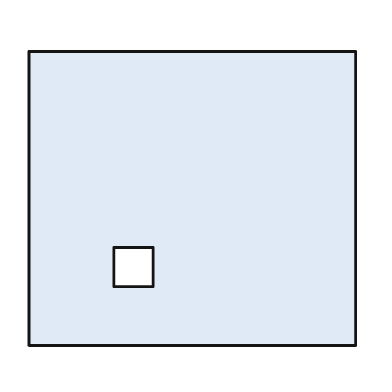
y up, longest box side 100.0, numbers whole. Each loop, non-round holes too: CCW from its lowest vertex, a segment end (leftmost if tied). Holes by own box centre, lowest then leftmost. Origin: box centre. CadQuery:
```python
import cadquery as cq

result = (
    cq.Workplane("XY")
    .moveTo(-50.0, -45.0)
    .lineTo(50.0, -45.0)
    .lineTo(50.0, 45.0)
    .lineTo(-50.0, 45.0)
    .close()
    .moveTo(-24.0, -27.0)
    .lineTo(-12.0, -27.0)
    .lineTo(-12.0, -15.0)
    .lineTo(-24.0, -15.0)
    .close()
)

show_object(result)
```